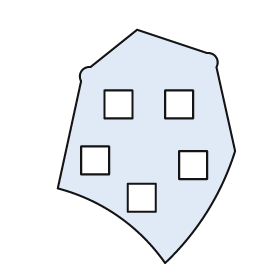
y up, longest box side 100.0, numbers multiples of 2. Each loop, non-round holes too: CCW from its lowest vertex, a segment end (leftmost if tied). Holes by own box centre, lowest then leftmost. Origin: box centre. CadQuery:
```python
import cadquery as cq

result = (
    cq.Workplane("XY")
    .moveTo(8.0, -50.0)
    .threePointArc((26.0, -28.0), (38.0, -2.0))
    .lineTo(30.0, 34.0)
    .threePointArc((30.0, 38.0), (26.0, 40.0))
    .lineTo(-4.0, 50.0)
    .lineTo(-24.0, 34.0)
    .threePointArc((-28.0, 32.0), (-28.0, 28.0))
    .lineTo(-38.0, -18.0)
    .threePointArc((-12.0, -30.0), (8.0, -50.0))
    .close()
    .moveTo(-8.0, -28.0)
    .lineTo(4.0, -28.0)
    .lineTo(4.0, -16.0)
    .lineTo(-8.0, -16.0)
    .close()
    .moveTo(14.0, -14.0)
    .lineTo(26.0, -14.0)
    .lineTo(26.0, -2.0)
    .lineTo(14.0, -2.0)
    .close()
    .moveTo(-28.0, -12.0)
    .lineTo(-16.0, -12.0)
    .lineTo(-16.0, 0.0)
    .lineTo(-28.0, 0.0)
    .close()
    .moveTo(-18.0, 12.0)
    .lineTo(-6.0, 12.0)
    .lineTo(-6.0, 24.0)
    .lineTo(-18.0, 24.0)
    .close()
    .moveTo(8.0, 12.0)
    .lineTo(20.0, 12.0)
    .lineTo(20.0, 24.0)
    .lineTo(8.0, 24.0)
    .close()
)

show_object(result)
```